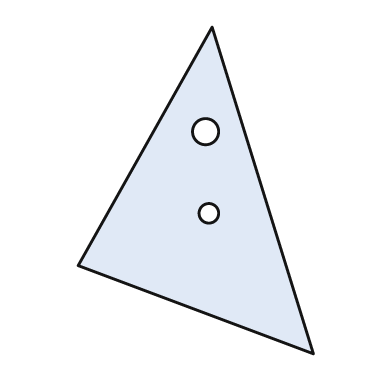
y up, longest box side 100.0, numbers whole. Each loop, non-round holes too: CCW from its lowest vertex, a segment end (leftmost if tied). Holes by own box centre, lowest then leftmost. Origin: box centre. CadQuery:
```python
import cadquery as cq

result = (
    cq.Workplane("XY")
    .moveTo(36.0, -50.0)
    .lineTo(5.0, 50.0)
    .lineTo(-36.0, -23.0)
    .close()
    .moveTo(4.0, -7.0)
    .circle(3.0)
    .moveTo(3.0, 18.0)
    .circle(4.0)
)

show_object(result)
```